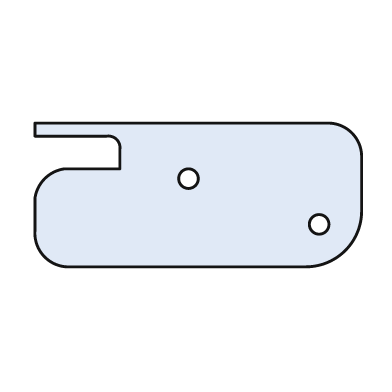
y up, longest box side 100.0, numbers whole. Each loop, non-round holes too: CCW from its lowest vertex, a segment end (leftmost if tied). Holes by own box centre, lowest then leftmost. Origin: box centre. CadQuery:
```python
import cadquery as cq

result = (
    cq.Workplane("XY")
    .moveTo(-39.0, -22.0)
    .lineTo(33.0, -22.0)
    .threePointArc((45.0, -17.0), (50.0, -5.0))
    .lineTo(50.0, 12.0)
    .threePointArc((47.0, 19.0), (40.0, 22.0))
    .lineTo(-50.0, 22.0)
    .lineTo(-50.0, 18.0)
    .lineTo(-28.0, 18.0)
    .threePointArc((-25.0, 17.0), (-24.0, 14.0))
    .lineTo(-24.0, 8.0)
    .lineTo(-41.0, 8.0)
    .threePointArc((-47.0, 5.0), (-50.0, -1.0))
    .lineTo(-50.0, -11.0)
    .threePointArc((-47.0, -19.0), (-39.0, -22.0))
    .close()
    .moveTo(37.0, -9.0)
    .circle(3.0)
    .moveTo(-3.0, 5.0)
    .circle(3.0)
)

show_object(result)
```